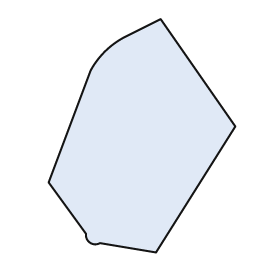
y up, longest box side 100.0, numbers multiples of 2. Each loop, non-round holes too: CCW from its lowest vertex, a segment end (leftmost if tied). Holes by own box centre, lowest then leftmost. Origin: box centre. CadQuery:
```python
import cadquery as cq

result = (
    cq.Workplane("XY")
    .moveTo(6.0, -50.0)
    .lineTo(40.0, 4.0)
    .lineTo(8.0, 50.0)
    .lineTo(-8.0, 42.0)
    .threePointArc((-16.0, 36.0), (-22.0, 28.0))
    .lineTo(-40.0, -20.0)
    .lineTo(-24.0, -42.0)
    .threePointArc((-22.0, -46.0), (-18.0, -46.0))
    .close()
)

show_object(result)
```